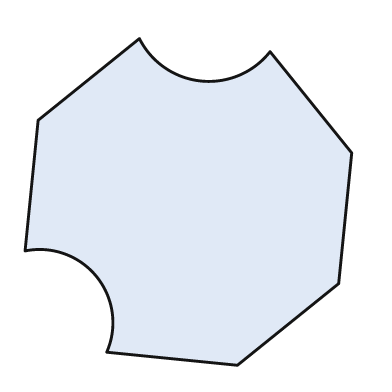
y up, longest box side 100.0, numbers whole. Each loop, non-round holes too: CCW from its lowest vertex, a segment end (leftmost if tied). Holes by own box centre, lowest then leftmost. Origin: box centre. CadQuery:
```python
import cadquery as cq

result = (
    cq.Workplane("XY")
    .moveTo(15.0, -50.0)
    .lineTo(46.0, -25.0)
    .lineTo(50.0, 15.0)
    .lineTo(25.0, 46.0)
    .threePointArc((4.0, 37.0), (-15.0, 50.0))
    .lineTo(-46.0, 25.0)
    .lineTo(-50.0, -15.0)
    .threePointArc((-28.0, -23.0), (-25.0, -46.0))
    .close()
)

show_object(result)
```